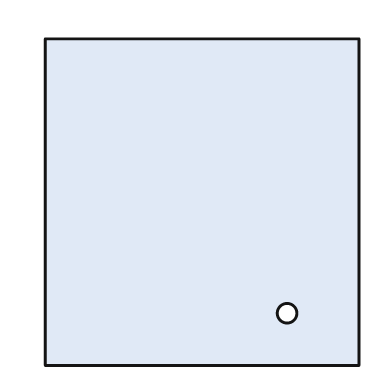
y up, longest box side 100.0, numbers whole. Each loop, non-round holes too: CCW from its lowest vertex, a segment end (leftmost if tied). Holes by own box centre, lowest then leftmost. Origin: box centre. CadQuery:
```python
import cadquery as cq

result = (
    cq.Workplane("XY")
    .moveTo(-48.0, -50.0)
    .lineTo(48.0, -50.0)
    .lineTo(48.0, 50.0)
    .lineTo(-48.0, 50.0)
    .close()
    .moveTo(26.0, -34.0)
    .circle(3.0)
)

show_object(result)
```